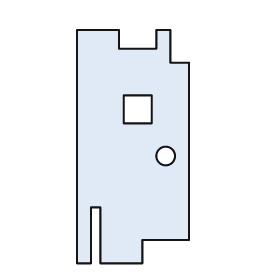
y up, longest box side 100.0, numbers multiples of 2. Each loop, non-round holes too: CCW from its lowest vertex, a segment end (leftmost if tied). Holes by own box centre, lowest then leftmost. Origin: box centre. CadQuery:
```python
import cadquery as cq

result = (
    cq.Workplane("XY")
    .moveTo(-24.0, -50.0)
    .lineTo(-18.0, -50.0)
    .lineTo(-18.0, -26.0)
    .lineTo(-14.0, -26.0)
    .lineTo(-14.0, -50.0)
    .lineTo(4.0, -50.0)
    .lineTo(4.0, -40.0)
    .lineTo(24.0, -40.0)
    .lineTo(24.0, 36.0)
    .lineTo(16.0, 36.0)
    .lineTo(16.0, 50.0)
    .lineTo(10.0, 50.0)
    .lineTo(10.0, 42.0)
    .lineTo(-6.0, 42.0)
    .lineTo(-6.0, 50.0)
    .lineTo(-24.0, 50.0)
    .close()
    .moveTo(14.0, -4.0)
    .circle(4.0)
    .moveTo(-4.0, 10.0)
    .lineTo(8.0, 10.0)
    .lineTo(8.0, 22.0)
    .lineTo(-4.0, 22.0)
    .close()
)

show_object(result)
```